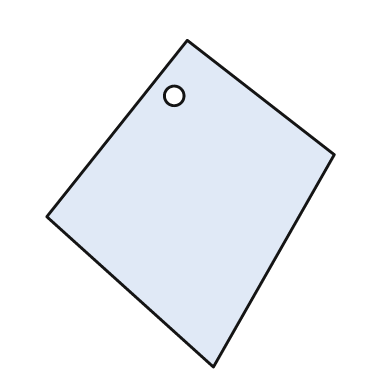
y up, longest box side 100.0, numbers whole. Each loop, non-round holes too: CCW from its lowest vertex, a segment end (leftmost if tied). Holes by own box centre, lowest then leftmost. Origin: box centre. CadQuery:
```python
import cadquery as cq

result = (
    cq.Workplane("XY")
    .moveTo(7.0, -50.0)
    .lineTo(44.0, 15.0)
    .lineTo(-1.0, 50.0)
    .lineTo(-44.0, -4.0)
    .close()
    .moveTo(-5.0, 33.0)
    .circle(3.0)
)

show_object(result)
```